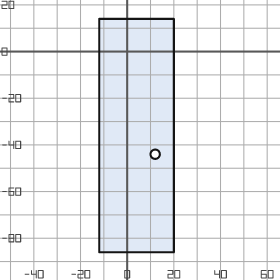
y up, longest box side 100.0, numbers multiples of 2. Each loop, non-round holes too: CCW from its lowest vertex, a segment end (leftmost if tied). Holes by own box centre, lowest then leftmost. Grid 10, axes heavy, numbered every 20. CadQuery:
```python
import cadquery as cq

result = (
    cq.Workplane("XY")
    .moveTo(-12.0, -86.0)
    .lineTo(20.0, -86.0)
    .lineTo(20.0, 14.0)
    .lineTo(-12.0, 14.0)
    .close()
    .moveTo(12.0, -44.0)
    .circle(2.0)
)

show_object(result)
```